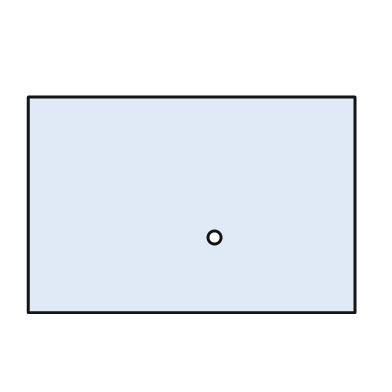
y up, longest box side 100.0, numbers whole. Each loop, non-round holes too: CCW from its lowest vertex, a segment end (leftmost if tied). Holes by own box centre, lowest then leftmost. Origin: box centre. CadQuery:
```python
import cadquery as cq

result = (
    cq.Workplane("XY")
    .moveTo(-50.0, -33.0)
    .lineTo(50.0, -33.0)
    .lineTo(50.0, 33.0)
    .lineTo(-50.0, 33.0)
    .close()
    .moveTo(7.0, -10.0)
    .circle(2.0)
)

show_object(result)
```